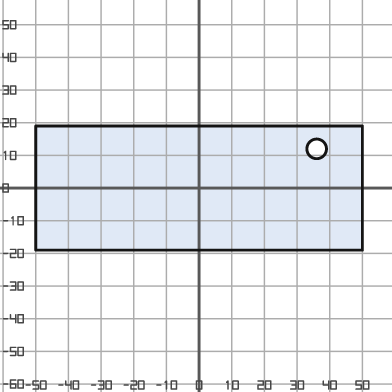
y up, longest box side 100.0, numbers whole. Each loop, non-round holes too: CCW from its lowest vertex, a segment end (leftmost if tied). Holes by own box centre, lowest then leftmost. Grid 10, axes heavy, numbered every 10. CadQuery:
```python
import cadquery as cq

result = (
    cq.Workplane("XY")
    .moveTo(-50.0, -19.0)
    .lineTo(50.0, -19.0)
    .lineTo(50.0, 19.0)
    .lineTo(-50.0, 19.0)
    .close()
    .moveTo(36.0, 12.0)
    .circle(3.0)
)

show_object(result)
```